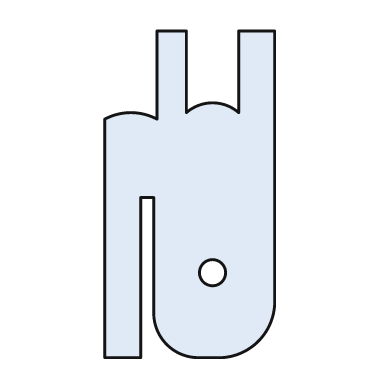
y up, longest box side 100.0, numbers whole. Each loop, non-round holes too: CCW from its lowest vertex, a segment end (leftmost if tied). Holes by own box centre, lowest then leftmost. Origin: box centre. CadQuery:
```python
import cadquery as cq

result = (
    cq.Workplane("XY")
    .moveTo(-26.0, -50.0)
    .lineTo(-15.0, -50.0)
    .lineTo(-15.0, -1.0)
    .lineTo(-11.0, -1.0)
    .lineTo(-11.0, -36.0)
    .threePointArc((-7.0, -46.0), (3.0, -50.0))
    .lineTo(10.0, -50.0)
    .threePointArc((21.0, -45.0), (26.0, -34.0))
    .lineTo(26.0, 50.0)
    .lineTo(15.0, 50.0)
    .lineTo(15.0, 25.0)
    .threePointArc((7.0, 28.0), (-1.0, 25.0))
    .lineTo(-1.0, 50.0)
    .lineTo(-10.0, 50.0)
    .lineTo(-10.0, 23.0)
    .threePointArc((-18.0, 25.0), (-26.0, 23.0))
    .close()
    .moveTo(7.0, -24.0)
    .circle(4.0)
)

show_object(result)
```